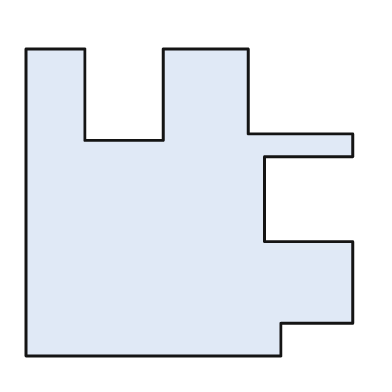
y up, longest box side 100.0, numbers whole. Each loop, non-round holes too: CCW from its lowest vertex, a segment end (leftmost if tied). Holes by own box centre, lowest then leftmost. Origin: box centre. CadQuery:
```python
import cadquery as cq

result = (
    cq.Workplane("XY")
    .moveTo(-50.0, -47.0)
    .lineTo(28.0, -47.0)
    .lineTo(28.0, -37.0)
    .lineTo(50.0, -37.0)
    .lineTo(50.0, -12.0)
    .lineTo(23.0, -12.0)
    .lineTo(23.0, 14.0)
    .lineTo(50.0, 14.0)
    .lineTo(50.0, 21.0)
    .lineTo(18.0, 21.0)
    .lineTo(18.0, 47.0)
    .lineTo(-8.0, 47.0)
    .lineTo(-8.0, 19.0)
    .lineTo(-32.0, 19.0)
    .lineTo(-32.0, 47.0)
    .lineTo(-50.0, 47.0)
    .close()
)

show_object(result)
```